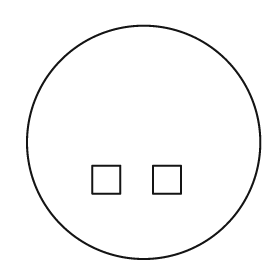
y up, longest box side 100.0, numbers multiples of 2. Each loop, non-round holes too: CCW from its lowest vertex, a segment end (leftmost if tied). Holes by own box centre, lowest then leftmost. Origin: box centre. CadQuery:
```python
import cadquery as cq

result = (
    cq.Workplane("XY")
    .moveTo(0.0, 0.0)
    .circle(50.0)
    .moveTo(-22.0, -22.0)
    .lineTo(-10.0, -22.0)
    .lineTo(-10.0, -10.0)
    .lineTo(-22.0, -10.0)
    .close()
    .moveTo(4.0, -22.0)
    .lineTo(16.0, -22.0)
    .lineTo(16.0, -10.0)
    .lineTo(4.0, -10.0)
    .close()
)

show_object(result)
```